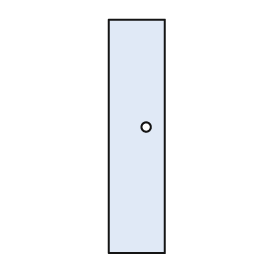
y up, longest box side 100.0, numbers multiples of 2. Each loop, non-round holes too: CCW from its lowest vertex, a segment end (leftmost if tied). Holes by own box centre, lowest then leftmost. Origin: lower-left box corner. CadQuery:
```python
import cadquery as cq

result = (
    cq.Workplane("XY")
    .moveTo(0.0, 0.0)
    .lineTo(24.0, 0.0)
    .lineTo(24.0, 100.0)
    .lineTo(0.0, 100.0)
    .close()
    .moveTo(16.0, 54.0)
    .circle(2.0)
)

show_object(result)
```